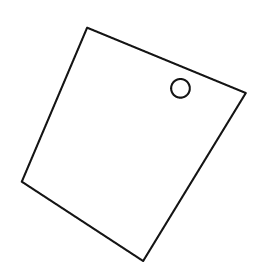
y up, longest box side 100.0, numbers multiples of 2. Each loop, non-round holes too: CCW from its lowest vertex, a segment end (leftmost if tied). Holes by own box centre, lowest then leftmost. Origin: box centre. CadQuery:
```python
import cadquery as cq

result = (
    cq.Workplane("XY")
    .moveTo(4.0, -50.0)
    .lineTo(48.0, 22.0)
    .lineTo(-20.0, 50.0)
    .lineTo(-48.0, -16.0)
    .close()
    .moveTo(20.0, 24.0)
    .circle(4.0)
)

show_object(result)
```